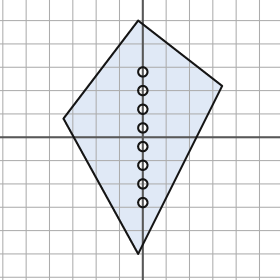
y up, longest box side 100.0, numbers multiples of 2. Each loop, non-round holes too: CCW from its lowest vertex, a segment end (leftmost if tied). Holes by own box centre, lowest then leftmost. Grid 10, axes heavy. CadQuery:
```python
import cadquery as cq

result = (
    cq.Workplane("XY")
    .moveTo(-2.0, -50.0)
    .lineTo(34.0, 22.0)
    .lineTo(-2.0, 50.0)
    .lineTo(-34.0, 8.0)
    .close()
    .moveTo(0.0, -28.0)
    .circle(2.0)
    .moveTo(0.0, -20.0)
    .circle(2.0)
    .moveTo(0.0, -12.0)
    .circle(2.0)
    .moveTo(0.0, -4.0)
    .circle(2.0)
    .moveTo(0.0, 4.0)
    .circle(2.0)
    .moveTo(0.0, 12.0)
    .circle(2.0)
    .moveTo(0.0, 20.0)
    .circle(2.0)
    .moveTo(0.0, 28.0)
    .circle(2.0)
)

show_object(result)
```